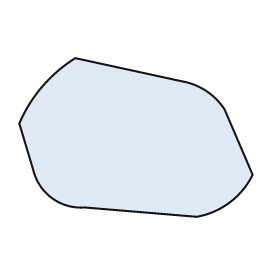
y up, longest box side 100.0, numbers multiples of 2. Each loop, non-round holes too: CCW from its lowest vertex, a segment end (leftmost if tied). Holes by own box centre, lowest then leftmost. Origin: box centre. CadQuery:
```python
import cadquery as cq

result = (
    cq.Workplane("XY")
    .moveTo(26.0, -34.0)
    .threePointArc((40.0, -28.0), (50.0, -16.0))
    .lineTo(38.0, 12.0)
    .threePointArc((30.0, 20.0), (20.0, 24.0))
    .lineTo(-26.0, 34.0)
    .threePointArc((-40.0, 22.0), (-50.0, 6.0))
    .lineTo(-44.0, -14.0)
    .threePointArc((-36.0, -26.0), (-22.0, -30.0))
    .close()
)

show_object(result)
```